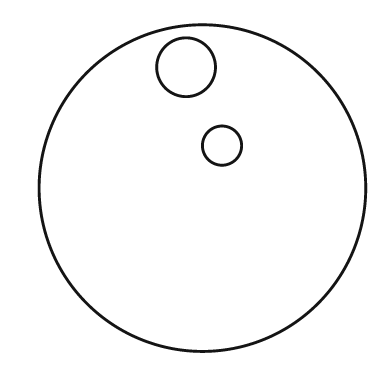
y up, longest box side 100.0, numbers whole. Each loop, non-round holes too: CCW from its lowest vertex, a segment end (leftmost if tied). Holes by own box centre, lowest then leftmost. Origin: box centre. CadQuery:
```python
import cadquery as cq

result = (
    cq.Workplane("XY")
    .moveTo(0.0, 0.0)
    .circle(50.0)
    .moveTo(6.0, 13.0)
    .circle(6.0)
    .moveTo(-5.0, 37.0)
    .circle(9.0)
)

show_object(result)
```